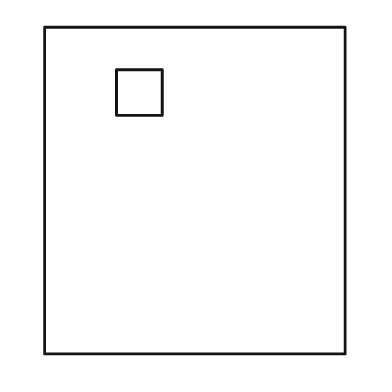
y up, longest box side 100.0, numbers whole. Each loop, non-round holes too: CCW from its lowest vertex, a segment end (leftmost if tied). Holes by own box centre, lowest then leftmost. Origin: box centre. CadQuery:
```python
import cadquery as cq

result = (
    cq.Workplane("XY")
    .moveTo(-46.0, -50.0)
    .lineTo(46.0, -50.0)
    .lineTo(46.0, 50.0)
    .lineTo(-46.0, 50.0)
    .close()
    .moveTo(-24.0, 23.0)
    .lineTo(-10.0, 23.0)
    .lineTo(-10.0, 37.0)
    .lineTo(-24.0, 37.0)
    .close()
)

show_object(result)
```